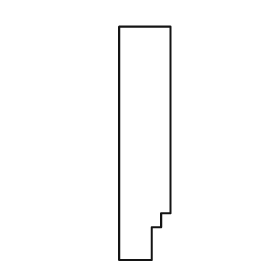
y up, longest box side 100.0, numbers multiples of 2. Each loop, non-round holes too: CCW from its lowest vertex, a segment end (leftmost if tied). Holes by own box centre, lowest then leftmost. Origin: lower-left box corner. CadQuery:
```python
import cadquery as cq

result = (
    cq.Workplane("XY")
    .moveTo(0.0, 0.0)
    .lineTo(14.0, 0.0)
    .lineTo(14.0, 14.0)
    .lineTo(18.0, 14.0)
    .lineTo(18.0, 20.0)
    .lineTo(22.0, 20.0)
    .lineTo(22.0, 100.0)
    .lineTo(0.0, 100.0)
    .close()
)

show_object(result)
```